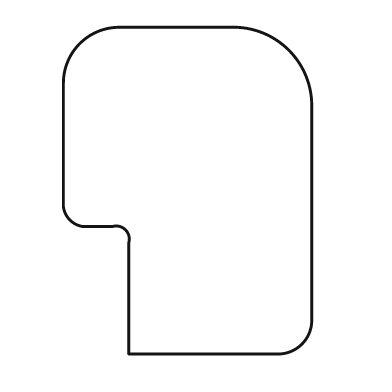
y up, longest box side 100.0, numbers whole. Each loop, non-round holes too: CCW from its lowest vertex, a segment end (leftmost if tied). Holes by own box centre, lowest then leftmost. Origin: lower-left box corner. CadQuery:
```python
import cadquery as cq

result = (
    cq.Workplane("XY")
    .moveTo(20.0, 0.0)
    .lineTo(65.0, 0.0)
    .threePointArc((73.0, 3.0), (76.0, 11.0))
    .lineTo(76.0, 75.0)
    .threePointArc((69.0, 93.0), (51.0, 100.0))
    .lineTo(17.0, 100.0)
    .threePointArc((5.0, 95.0), (0.0, 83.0))
    .lineTo(0.0, 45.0)
    .threePointArc((2.0, 41.0), (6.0, 39.0))
    .lineTo(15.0, 39.0)
    .threePointArc((19.0, 38.0), (20.0, 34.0))
    .close()
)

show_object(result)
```